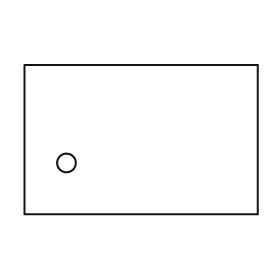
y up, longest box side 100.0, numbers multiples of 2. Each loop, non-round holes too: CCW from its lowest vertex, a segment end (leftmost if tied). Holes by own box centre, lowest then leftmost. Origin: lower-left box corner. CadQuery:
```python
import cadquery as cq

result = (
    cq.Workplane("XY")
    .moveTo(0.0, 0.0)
    .lineTo(100.0, 0.0)
    .lineTo(100.0, 64.0)
    .lineTo(0.0, 64.0)
    .close()
    .moveTo(18.0, 22.0)
    .circle(4.0)
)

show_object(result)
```